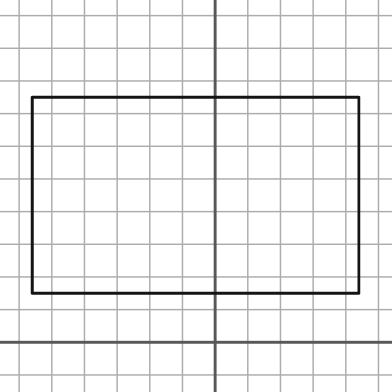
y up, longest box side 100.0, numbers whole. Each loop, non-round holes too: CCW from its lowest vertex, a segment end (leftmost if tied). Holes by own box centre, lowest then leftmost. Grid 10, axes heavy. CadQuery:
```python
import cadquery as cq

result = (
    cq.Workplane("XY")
    .moveTo(-56.0, 15.0)
    .lineTo(44.0, 15.0)
    .lineTo(44.0, 75.0)
    .lineTo(-56.0, 75.0)
    .close()
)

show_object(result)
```